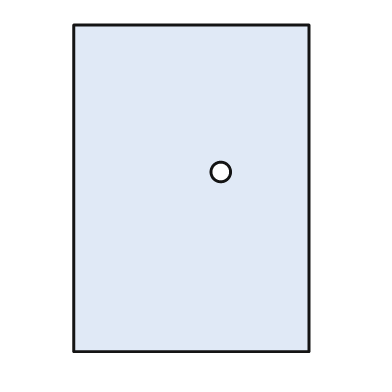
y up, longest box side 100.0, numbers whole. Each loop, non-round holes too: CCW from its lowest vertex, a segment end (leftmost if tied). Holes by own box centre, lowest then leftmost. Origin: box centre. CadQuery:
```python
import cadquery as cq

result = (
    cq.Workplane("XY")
    .moveTo(-36.0, -50.0)
    .lineTo(36.0, -50.0)
    .lineTo(36.0, 50.0)
    .lineTo(-36.0, 50.0)
    .close()
    .moveTo(9.0, 5.0)
    .circle(3.0)
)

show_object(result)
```